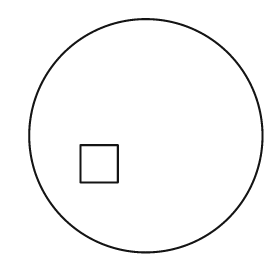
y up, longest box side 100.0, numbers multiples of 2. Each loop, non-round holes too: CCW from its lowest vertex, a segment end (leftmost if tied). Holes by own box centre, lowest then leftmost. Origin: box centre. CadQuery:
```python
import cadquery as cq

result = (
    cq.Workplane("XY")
    .moveTo(0.0, 0.0)
    .circle(50.0)
    .moveTo(-28.0, -20.0)
    .lineTo(-12.0, -20.0)
    .lineTo(-12.0, -4.0)
    .lineTo(-28.0, -4.0)
    .close()
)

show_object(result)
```